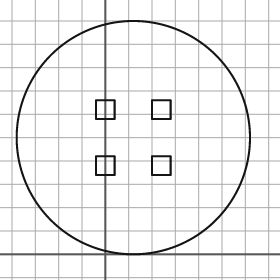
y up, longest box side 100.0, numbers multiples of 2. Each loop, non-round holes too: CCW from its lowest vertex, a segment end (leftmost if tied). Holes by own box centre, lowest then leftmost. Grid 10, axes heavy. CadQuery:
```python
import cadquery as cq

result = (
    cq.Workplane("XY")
    .moveTo(12.0, 50.0)
    .circle(50.0)
    .moveTo(-4.0, 34.0)
    .lineTo(4.0, 34.0)
    .lineTo(4.0, 42.0)
    .lineTo(-4.0, 42.0)
    .close()
    .moveTo(20.0, 34.0)
    .lineTo(28.0, 34.0)
    .lineTo(28.0, 42.0)
    .lineTo(20.0, 42.0)
    .close()
    .moveTo(-4.0, 58.0)
    .lineTo(4.0, 58.0)
    .lineTo(4.0, 66.0)
    .lineTo(-4.0, 66.0)
    .close()
    .moveTo(20.0, 58.0)
    .lineTo(28.0, 58.0)
    .lineTo(28.0, 66.0)
    .lineTo(20.0, 66.0)
    .close()
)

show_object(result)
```